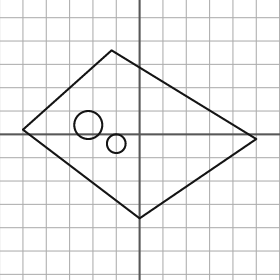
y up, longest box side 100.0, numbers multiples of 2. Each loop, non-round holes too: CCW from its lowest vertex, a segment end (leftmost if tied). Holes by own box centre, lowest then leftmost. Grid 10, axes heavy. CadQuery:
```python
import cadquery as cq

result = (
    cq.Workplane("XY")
    .moveTo(0.0, -36.0)
    .lineTo(50.0, -2.0)
    .lineTo(-12.0, 36.0)
    .lineTo(-50.0, 2.0)
    .close()
    .moveTo(-10.0, -4.0)
    .circle(4.0)
    .moveTo(-22.0, 4.0)
    .circle(6.0)
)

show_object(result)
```